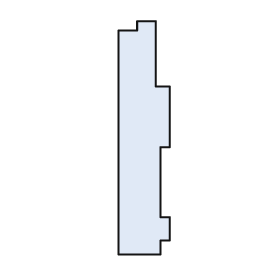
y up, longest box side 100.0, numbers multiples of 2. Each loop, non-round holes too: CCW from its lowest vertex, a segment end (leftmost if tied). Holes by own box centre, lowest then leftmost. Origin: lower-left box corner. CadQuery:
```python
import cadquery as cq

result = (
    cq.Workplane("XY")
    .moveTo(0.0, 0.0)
    .lineTo(18.0, 0.0)
    .lineTo(18.0, 6.0)
    .lineTo(22.0, 6.0)
    .lineTo(22.0, 16.0)
    .lineTo(18.0, 16.0)
    .lineTo(18.0, 46.0)
    .lineTo(22.0, 46.0)
    .lineTo(22.0, 72.0)
    .lineTo(16.0, 72.0)
    .lineTo(16.0, 100.0)
    .lineTo(8.0, 100.0)
    .lineTo(8.0, 96.0)
    .lineTo(0.0, 96.0)
    .close()
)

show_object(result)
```